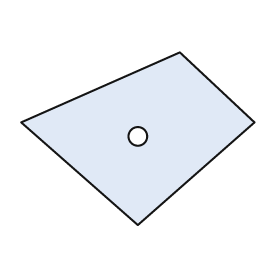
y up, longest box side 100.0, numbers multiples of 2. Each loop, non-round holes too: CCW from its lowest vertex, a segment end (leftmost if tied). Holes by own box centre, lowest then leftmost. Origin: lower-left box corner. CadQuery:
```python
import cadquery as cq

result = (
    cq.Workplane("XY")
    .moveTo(50.0, 0.0)
    .lineTo(100.0, 44.0)
    .lineTo(68.0, 74.0)
    .lineTo(0.0, 44.0)
    .close()
    .moveTo(50.0, 38.0)
    .circle(4.0)
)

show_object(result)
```